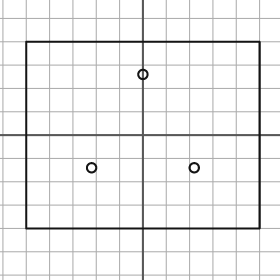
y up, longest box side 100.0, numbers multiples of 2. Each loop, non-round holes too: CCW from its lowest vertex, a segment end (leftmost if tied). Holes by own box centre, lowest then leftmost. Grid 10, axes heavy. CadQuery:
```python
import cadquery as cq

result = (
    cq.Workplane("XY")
    .moveTo(-50.0, -40.0)
    .lineTo(50.0, -40.0)
    .lineTo(50.0, 40.0)
    .lineTo(-50.0, 40.0)
    .close()
    .moveTo(-22.0, -14.0)
    .circle(2.0)
    .moveTo(22.0, -14.0)
    .circle(2.0)
    .moveTo(0.0, 26.0)
    .circle(2.0)
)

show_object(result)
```